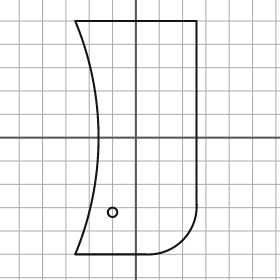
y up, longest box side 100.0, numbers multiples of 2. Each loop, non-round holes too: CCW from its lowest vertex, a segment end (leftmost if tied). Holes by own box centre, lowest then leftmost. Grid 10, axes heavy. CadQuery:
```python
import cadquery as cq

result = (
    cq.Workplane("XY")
    .moveTo(-26.0, -50.0)
    .lineTo(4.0, -50.0)
    .threePointArc((20.0, -44.0), (26.0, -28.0))
    .lineTo(26.0, 50.0)
    .lineTo(-26.0, 50.0)
    .threePointArc((-16.0, 0.0), (-26.0, -50.0))
    .close()
    .moveTo(-10.0, -32.0)
    .circle(2.0)
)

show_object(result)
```